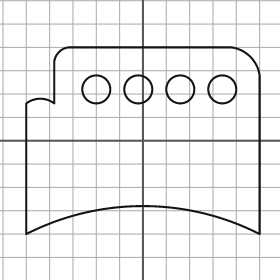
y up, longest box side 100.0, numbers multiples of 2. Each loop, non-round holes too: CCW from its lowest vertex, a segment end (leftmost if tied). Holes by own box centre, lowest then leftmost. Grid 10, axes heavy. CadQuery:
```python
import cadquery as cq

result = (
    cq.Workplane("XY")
    .moveTo(-50.0, -40.0)
    .threePointArc((0.0, -28.0), (50.0, -40.0))
    .lineTo(50.0, 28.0)
    .threePointArc((46.0, 36.0), (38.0, 40.0))
    .lineTo(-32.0, 40.0)
    .threePointArc((-36.0, 38.0), (-38.0, 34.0))
    .lineTo(-38.0, 16.0)
    .threePointArc((-44.0, 18.0), (-50.0, 16.0))
    .close()
    .moveTo(-20.0, 22.0)
    .circle(6.0)
    .moveTo(-2.0, 22.0)
    .circle(6.0)
    .moveTo(16.0, 22.0)
    .circle(6.0)
    .moveTo(34.0, 22.0)
    .circle(6.0)
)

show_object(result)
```